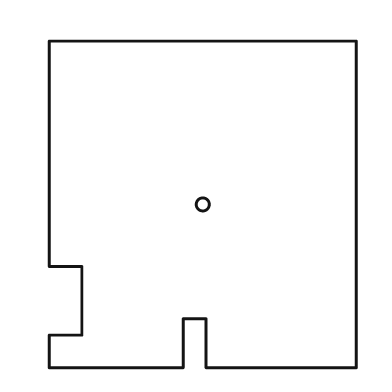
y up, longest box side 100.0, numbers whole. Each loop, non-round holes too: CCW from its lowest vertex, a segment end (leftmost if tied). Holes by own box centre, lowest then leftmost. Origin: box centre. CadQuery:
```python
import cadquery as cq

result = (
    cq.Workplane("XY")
    .moveTo(-47.0, -50.0)
    .lineTo(-6.0, -50.0)
    .lineTo(-6.0, -35.0)
    .lineTo(1.0, -35.0)
    .lineTo(1.0, -50.0)
    .lineTo(47.0, -50.0)
    .lineTo(47.0, 50.0)
    .lineTo(-47.0, 50.0)
    .lineTo(-47.0, -19.0)
    .lineTo(-37.0, -19.0)
    .lineTo(-37.0, -40.0)
    .lineTo(-47.0, -40.0)
    .close()
    .moveTo(0.0, 0.0)
    .circle(2.0)
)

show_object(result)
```